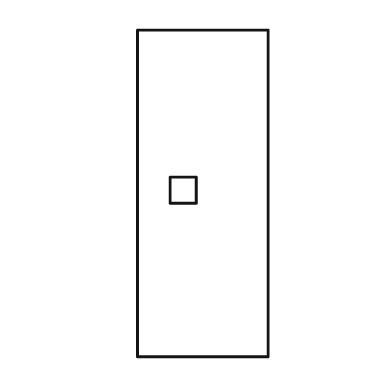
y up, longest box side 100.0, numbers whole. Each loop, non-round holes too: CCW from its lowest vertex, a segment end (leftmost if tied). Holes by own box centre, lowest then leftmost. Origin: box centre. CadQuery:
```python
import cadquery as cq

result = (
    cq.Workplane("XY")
    .moveTo(-20.0, -50.0)
    .lineTo(20.0, -50.0)
    .lineTo(20.0, 50.0)
    .lineTo(-20.0, 50.0)
    .close()
    .moveTo(-10.0, -3.0)
    .lineTo(-2.0, -3.0)
    .lineTo(-2.0, 5.0)
    .lineTo(-10.0, 5.0)
    .close()
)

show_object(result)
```